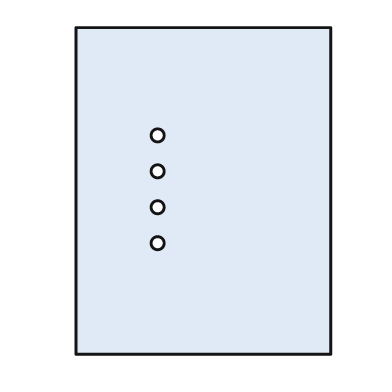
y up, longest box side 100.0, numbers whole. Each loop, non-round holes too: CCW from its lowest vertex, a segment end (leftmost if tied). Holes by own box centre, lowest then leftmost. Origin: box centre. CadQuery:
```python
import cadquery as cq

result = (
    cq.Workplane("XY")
    .moveTo(-39.0, -50.0)
    .lineTo(39.0, -50.0)
    .lineTo(39.0, 50.0)
    .lineTo(-39.0, 50.0)
    .close()
    .moveTo(-14.0, -16.0)
    .circle(2.0)
    .moveTo(-14.0, -5.0)
    .circle(2.0)
    .moveTo(-14.0, 6.0)
    .circle(2.0)
    .moveTo(-14.0, 17.0)
    .circle(2.0)
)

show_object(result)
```